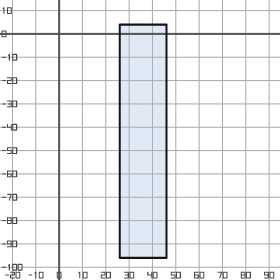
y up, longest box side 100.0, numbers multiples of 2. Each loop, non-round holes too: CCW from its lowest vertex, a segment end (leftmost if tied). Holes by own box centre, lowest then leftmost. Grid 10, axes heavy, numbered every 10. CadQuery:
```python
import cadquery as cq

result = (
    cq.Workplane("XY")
    .moveTo(26.0, -96.0)
    .lineTo(46.0, -96.0)
    .lineTo(46.0, 4.0)
    .lineTo(26.0, 4.0)
    .close()
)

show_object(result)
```